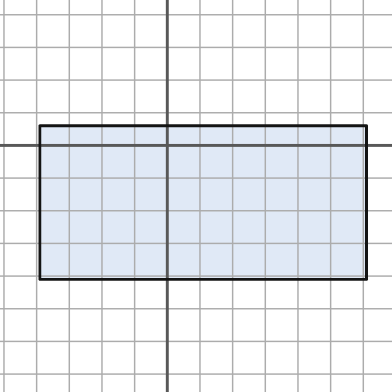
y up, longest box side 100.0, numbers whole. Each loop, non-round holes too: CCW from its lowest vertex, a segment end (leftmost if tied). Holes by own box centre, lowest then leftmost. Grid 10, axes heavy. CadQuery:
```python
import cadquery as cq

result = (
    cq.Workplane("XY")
    .moveTo(-39.0, -41.0)
    .lineTo(61.0, -41.0)
    .lineTo(61.0, 6.0)
    .lineTo(-39.0, 6.0)
    .close()
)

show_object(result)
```